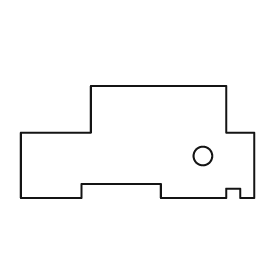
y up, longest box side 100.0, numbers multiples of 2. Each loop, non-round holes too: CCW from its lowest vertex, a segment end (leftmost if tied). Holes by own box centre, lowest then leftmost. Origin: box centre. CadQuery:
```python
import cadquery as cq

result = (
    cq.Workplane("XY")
    .moveTo(-50.0, -24.0)
    .lineTo(-24.0, -24.0)
    .lineTo(-24.0, -18.0)
    .lineTo(10.0, -18.0)
    .lineTo(10.0, -24.0)
    .lineTo(38.0, -24.0)
    .lineTo(38.0, -20.0)
    .lineTo(44.0, -20.0)
    .lineTo(44.0, -24.0)
    .lineTo(50.0, -24.0)
    .lineTo(50.0, 4.0)
    .lineTo(38.0, 4.0)
    .lineTo(38.0, 24.0)
    .lineTo(-20.0, 24.0)
    .lineTo(-20.0, 4.0)
    .lineTo(-50.0, 4.0)
    .close()
    .moveTo(28.0, -6.0)
    .circle(4.0)
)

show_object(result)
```